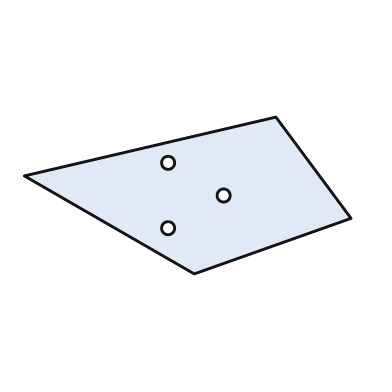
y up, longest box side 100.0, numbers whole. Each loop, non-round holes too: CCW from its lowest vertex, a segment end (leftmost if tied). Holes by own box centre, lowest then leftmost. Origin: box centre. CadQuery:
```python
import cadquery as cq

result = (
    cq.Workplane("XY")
    .moveTo(2.0, -24.0)
    .lineTo(50.0, -7.0)
    .lineTo(27.0, 24.0)
    .lineTo(-50.0, 6.0)
    .close()
    .moveTo(-6.0, -10.0)
    .circle(2.0)
    .moveTo(11.0, 0.0)
    .circle(2.0)
    .moveTo(-6.0, 10.0)
    .circle(2.0)
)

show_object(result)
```